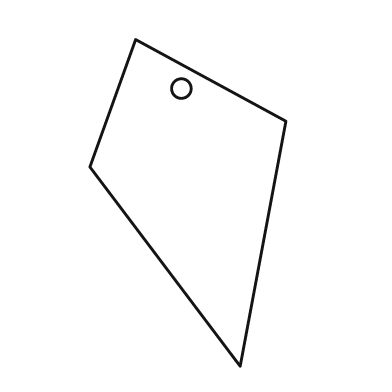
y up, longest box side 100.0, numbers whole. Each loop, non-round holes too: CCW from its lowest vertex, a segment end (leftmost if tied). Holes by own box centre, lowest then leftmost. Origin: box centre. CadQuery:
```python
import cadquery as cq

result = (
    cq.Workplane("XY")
    .moveTo(16.0, -50.0)
    .lineTo(30.0, 25.0)
    .lineTo(-16.0, 50.0)
    .lineTo(-30.0, 11.0)
    .close()
    .moveTo(-2.0, 35.0)
    .circle(3.0)
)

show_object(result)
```